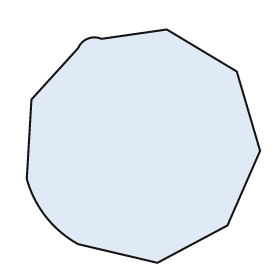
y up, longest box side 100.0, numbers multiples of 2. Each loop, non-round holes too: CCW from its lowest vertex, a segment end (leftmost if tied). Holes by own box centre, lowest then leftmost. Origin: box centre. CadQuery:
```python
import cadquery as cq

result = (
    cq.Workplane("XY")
    .moveTo(6.0, -50.0)
    .lineTo(36.0, -34.0)
    .lineTo(50.0, -2.0)
    .lineTo(40.0, 32.0)
    .lineTo(10.0, 50.0)
    .lineTo(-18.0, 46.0)
    .threePointArc((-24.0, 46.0), (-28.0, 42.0))
    .lineTo(-48.0, 20.0)
    .lineTo(-50.0, -14.0)
    .threePointArc((-42.0, -30.0), (-28.0, -42.0))
    .close()
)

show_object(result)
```